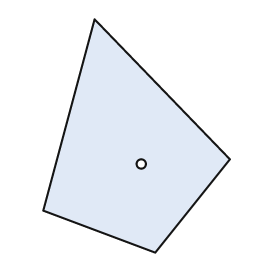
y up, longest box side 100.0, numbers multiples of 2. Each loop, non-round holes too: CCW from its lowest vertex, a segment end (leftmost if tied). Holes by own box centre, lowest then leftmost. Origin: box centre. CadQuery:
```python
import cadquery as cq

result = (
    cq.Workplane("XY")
    .moveTo(8.0, -50.0)
    .lineTo(40.0, -10.0)
    .lineTo(-18.0, 50.0)
    .lineTo(-40.0, -32.0)
    .close()
    .moveTo(2.0, -12.0)
    .circle(2.0)
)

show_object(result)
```